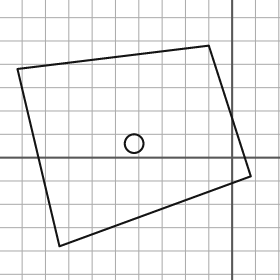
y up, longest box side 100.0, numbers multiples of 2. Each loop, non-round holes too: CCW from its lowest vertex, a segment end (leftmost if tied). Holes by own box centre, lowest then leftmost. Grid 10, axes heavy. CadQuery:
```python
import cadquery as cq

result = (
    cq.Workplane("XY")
    .moveTo(-74.0, -38.0)
    .lineTo(8.0, -8.0)
    .lineTo(-10.0, 48.0)
    .lineTo(-92.0, 38.0)
    .close()
    .moveTo(-42.0, 6.0)
    .circle(4.0)
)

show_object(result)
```